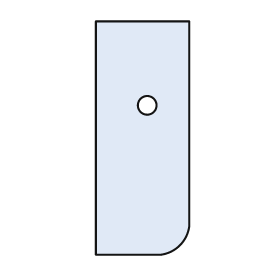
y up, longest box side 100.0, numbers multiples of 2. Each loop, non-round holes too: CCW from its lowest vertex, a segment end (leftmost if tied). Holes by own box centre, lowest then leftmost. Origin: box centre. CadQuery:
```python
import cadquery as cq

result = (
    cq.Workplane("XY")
    .moveTo(-20.0, -50.0)
    .lineTo(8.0, -50.0)
    .threePointArc((16.0, -46.0), (20.0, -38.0))
    .lineTo(20.0, 50.0)
    .lineTo(-20.0, 50.0)
    .close()
    .moveTo(2.0, 14.0)
    .circle(4.0)
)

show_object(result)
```